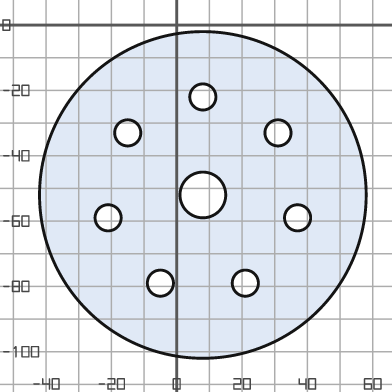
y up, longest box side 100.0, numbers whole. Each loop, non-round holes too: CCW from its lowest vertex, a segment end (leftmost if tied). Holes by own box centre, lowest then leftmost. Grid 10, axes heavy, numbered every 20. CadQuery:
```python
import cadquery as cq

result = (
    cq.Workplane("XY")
    .moveTo(8.0, -52.0)
    .circle(50.0)
    .moveTo(-5.0, -79.0)
    .circle(4.0)
    .moveTo(21.0, -79.0)
    .circle(4.0)
    .moveTo(-21.0, -59.0)
    .circle(4.0)
    .moveTo(37.0, -59.0)
    .circle(4.0)
    .moveTo(8.0, -52.0)
    .circle(7.0)
    .moveTo(-15.0, -33.0)
    .circle(4.0)
    .moveTo(31.0, -33.0)
    .circle(4.0)
    .moveTo(8.0, -22.0)
    .circle(4.0)
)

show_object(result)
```